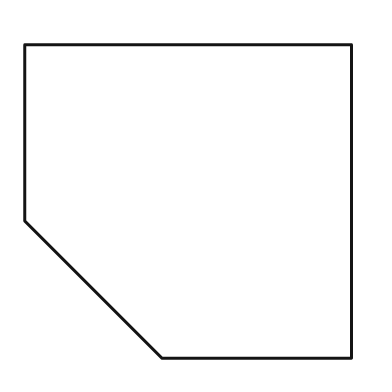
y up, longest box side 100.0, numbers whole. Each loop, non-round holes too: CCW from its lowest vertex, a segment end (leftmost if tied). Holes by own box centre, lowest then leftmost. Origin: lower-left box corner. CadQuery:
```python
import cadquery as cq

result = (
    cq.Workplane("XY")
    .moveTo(42.0, 0.0)
    .lineTo(100.0, 0.0)
    .lineTo(100.0, 96.0)
    .lineTo(0.0, 96.0)
    .lineTo(0.0, 42.0)
    .close()
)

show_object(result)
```